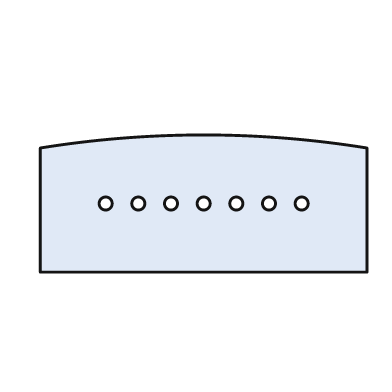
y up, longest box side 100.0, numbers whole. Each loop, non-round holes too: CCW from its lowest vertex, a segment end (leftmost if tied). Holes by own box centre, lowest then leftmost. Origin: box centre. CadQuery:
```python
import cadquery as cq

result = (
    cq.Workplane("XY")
    .moveTo(-50.0, -21.0)
    .lineTo(50.0, -21.0)
    .lineTo(50.0, 17.0)
    .threePointArc((0.0, 21.0), (-50.0, 17.0))
    .close()
    .moveTo(-30.0, 0.0)
    .circle(2.0)
    .moveTo(-20.0, 0.0)
    .circle(2.0)
    .moveTo(-10.0, 0.0)
    .circle(2.0)
    .moveTo(0.0, 0.0)
    .circle(2.0)
    .moveTo(10.0, 0.0)
    .circle(2.0)
    .moveTo(20.0, 0.0)
    .circle(2.0)
    .moveTo(30.0, 0.0)
    .circle(2.0)
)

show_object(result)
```